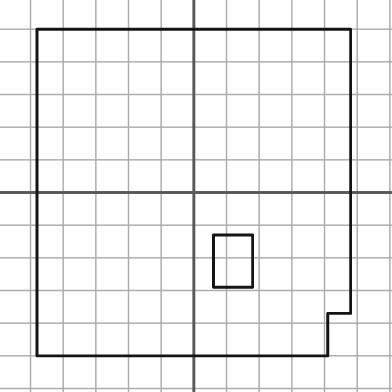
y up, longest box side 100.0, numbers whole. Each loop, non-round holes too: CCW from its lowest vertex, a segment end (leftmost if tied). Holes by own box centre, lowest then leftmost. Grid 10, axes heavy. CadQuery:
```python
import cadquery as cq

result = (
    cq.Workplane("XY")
    .moveTo(-48.0, -50.0)
    .lineTo(41.0, -50.0)
    .lineTo(41.0, -37.0)
    .lineTo(48.0, -37.0)
    .lineTo(48.0, 50.0)
    .lineTo(-48.0, 50.0)
    .close()
    .moveTo(6.0, -29.0)
    .lineTo(18.0, -29.0)
    .lineTo(18.0, -13.0)
    .lineTo(6.0, -13.0)
    .close()
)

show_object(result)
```